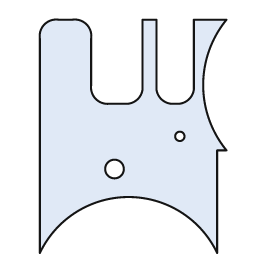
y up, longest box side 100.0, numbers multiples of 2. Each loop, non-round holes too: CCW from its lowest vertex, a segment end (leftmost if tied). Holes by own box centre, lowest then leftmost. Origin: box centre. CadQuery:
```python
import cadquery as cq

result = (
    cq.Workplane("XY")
    .moveTo(-40.0, -50.0)
    .threePointArc((-2.0, -26.0), (36.0, -50.0))
    .lineTo(36.0, -6.0)
    .lineTo(40.0, -6.0)
    .threePointArc((30.0, 22.0), (40.0, 50.0))
    .lineTo(26.0, 50.0)
    .lineTo(26.0, 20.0)
    .threePointArc((24.0, 16.0), (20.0, 14.0))
    .lineTo(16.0, 14.0)
    .threePointArc((12.0, 16.0), (10.0, 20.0))
    .lineTo(10.0, 50.0)
    .lineTo(4.0, 50.0)
    .lineTo(4.0, 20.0)
    .threePointArc((2.0, 16.0), (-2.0, 14.0))
    .lineTo(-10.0, 14.0)
    .threePointArc((-16.0, 16.0), (-18.0, 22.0))
    .lineTo(-18.0, 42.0)
    .threePointArc((-20.0, 48.0), (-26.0, 50.0))
    .lineTo(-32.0, 50.0)
    .threePointArc((-38.0, 48.0), (-40.0, 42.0))
    .close()
    .moveTo(-8.0, -14.0)
    .circle(4.0)
    .moveTo(20.0, 0.0)
    .circle(2.0)
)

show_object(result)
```